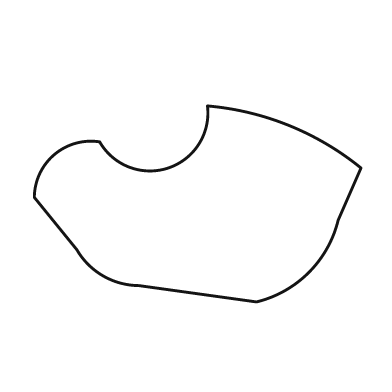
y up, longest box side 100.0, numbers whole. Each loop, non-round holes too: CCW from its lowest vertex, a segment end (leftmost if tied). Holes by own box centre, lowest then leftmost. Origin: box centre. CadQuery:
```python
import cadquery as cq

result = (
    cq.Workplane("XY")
    .moveTo(18.0, -30.0)
    .threePointArc((34.0, -21.0), (43.0, -5.0))
    .lineTo(50.0, 11.0)
    .threePointArc((28.0, 24.0), (3.0, 30.0))
    .threePointArc((-9.0, 11.0), (-30.0, 19.0))
    .threePointArc((-44.0, 15.0), (-50.0, 2.0))
    .lineTo(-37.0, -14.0)
    .threePointArc((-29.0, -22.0), (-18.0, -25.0))
    .close()
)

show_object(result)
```